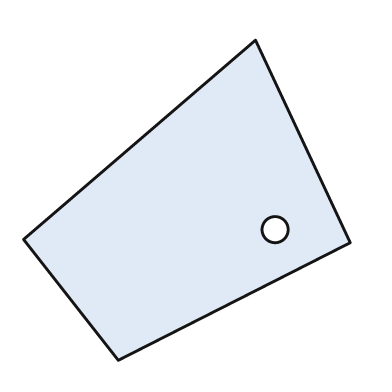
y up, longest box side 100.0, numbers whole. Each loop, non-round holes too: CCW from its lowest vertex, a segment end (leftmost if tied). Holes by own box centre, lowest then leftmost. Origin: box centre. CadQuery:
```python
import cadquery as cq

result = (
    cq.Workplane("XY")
    .moveTo(-21.0, -49.0)
    .lineTo(50.0, -13.0)
    .lineTo(21.0, 49.0)
    .lineTo(-50.0, -12.0)
    .close()
    .moveTo(27.0, -9.0)
    .circle(4.0)
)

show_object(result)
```